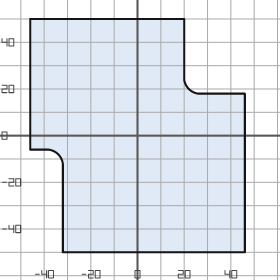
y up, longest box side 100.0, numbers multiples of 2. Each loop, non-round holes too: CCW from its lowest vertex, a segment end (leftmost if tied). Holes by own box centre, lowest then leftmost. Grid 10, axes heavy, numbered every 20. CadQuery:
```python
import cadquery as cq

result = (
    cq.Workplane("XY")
    .moveTo(-32.0, -50.0)
    .lineTo(46.0, -50.0)
    .lineTo(46.0, 18.0)
    .lineTo(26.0, 18.0)
    .threePointArc((22.0, 20.0), (20.0, 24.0))
    .lineTo(20.0, 50.0)
    .lineTo(-46.0, 50.0)
    .lineTo(-46.0, -6.0)
    .lineTo(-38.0, -6.0)
    .threePointArc((-34.0, -8.0), (-32.0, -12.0))
    .close()
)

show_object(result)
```